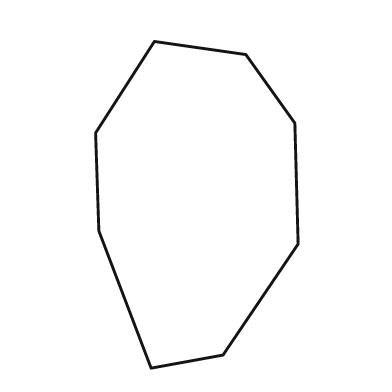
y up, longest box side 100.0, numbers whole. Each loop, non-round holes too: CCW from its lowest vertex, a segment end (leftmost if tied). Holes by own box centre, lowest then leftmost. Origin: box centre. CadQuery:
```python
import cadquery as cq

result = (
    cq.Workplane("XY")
    .moveTo(-14.0, -50.0)
    .lineTo(8.0, -46.0)
    .lineTo(31.0, -12.0)
    .lineTo(30.0, 25.0)
    .lineTo(15.0, 46.0)
    .lineTo(-13.0, 50.0)
    .lineTo(-31.0, 22.0)
    .lineTo(-30.0, -8.0)
    .close()
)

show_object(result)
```